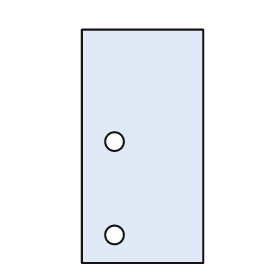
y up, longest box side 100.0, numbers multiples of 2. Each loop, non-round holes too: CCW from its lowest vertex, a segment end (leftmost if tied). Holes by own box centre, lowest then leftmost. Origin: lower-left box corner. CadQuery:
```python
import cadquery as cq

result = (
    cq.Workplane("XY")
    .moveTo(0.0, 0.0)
    .lineTo(52.0, 0.0)
    .lineTo(52.0, 100.0)
    .lineTo(0.0, 100.0)
    .close()
    .moveTo(14.0, 12.0)
    .circle(4.0)
    .moveTo(14.0, 52.0)
    .circle(4.0)
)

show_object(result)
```